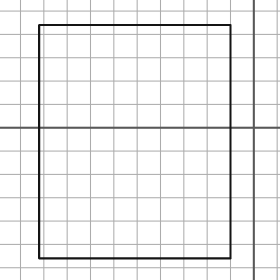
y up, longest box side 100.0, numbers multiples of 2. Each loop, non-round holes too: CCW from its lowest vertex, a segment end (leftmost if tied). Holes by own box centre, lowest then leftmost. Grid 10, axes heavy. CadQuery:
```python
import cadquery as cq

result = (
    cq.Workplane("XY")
    .moveTo(-92.0, -56.0)
    .lineTo(-10.0, -56.0)
    .lineTo(-10.0, 44.0)
    .lineTo(-92.0, 44.0)
    .close()
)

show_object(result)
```